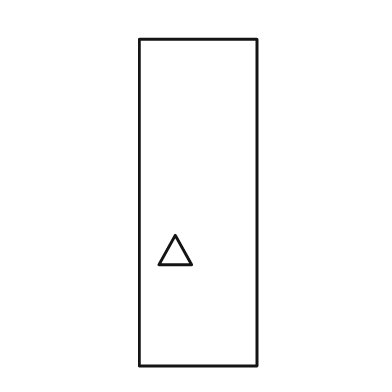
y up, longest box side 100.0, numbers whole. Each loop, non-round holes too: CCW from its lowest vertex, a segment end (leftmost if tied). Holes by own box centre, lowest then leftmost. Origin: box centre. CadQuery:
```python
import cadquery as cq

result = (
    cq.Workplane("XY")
    .moveTo(-18.0, -50.0)
    .lineTo(18.0, -50.0)
    .lineTo(18.0, 50.0)
    .lineTo(-18.0, 50.0)
    .close()
    .moveTo(-12.0, -19.0)
    .lineTo(-2.0, -19.0)
    .lineTo(-7.0, -10.0)
    .close()
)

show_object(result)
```